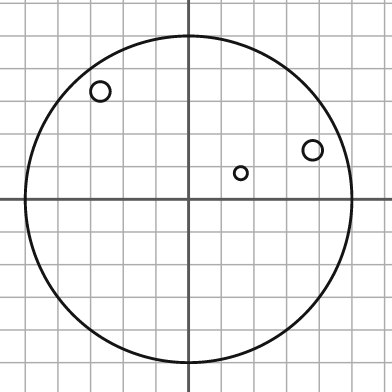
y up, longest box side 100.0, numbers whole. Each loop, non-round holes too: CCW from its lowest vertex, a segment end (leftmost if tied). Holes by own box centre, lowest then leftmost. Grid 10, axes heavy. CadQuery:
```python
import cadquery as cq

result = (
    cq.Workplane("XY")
    .moveTo(0.0, 0.0)
    .circle(50.0)
    .moveTo(16.0, 8.0)
    .circle(2.0)
    .moveTo(38.0, 15.0)
    .circle(3.0)
    .moveTo(-27.0, 33.0)
    .circle(3.0)
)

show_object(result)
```